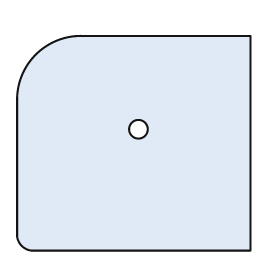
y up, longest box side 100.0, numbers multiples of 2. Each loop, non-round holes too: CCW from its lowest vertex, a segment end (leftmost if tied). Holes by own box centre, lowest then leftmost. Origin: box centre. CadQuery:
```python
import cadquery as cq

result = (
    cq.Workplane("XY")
    .moveTo(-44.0, -46.0)
    .lineTo(50.0, -46.0)
    .lineTo(50.0, 46.0)
    .lineTo(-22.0, 46.0)
    .threePointArc((-42.0, 38.0), (-50.0, 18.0))
    .lineTo(-50.0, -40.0)
    .threePointArc((-48.0, -44.0), (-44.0, -46.0))
    .close()
    .moveTo(2.0, 6.0)
    .circle(4.0)
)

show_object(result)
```